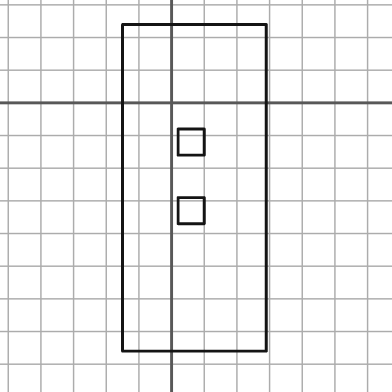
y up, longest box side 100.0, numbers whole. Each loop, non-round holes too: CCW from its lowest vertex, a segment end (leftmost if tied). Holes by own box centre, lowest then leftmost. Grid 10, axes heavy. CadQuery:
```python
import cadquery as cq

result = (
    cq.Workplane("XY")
    .moveTo(-15.0, -76.0)
    .lineTo(29.0, -76.0)
    .lineTo(29.0, 24.0)
    .lineTo(-15.0, 24.0)
    .close()
    .moveTo(2.0, -37.0)
    .lineTo(10.0, -37.0)
    .lineTo(10.0, -29.0)
    .lineTo(2.0, -29.0)
    .close()
    .moveTo(2.0, -16.0)
    .lineTo(10.0, -16.0)
    .lineTo(10.0, -8.0)
    .lineTo(2.0, -8.0)
    .close()
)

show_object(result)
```